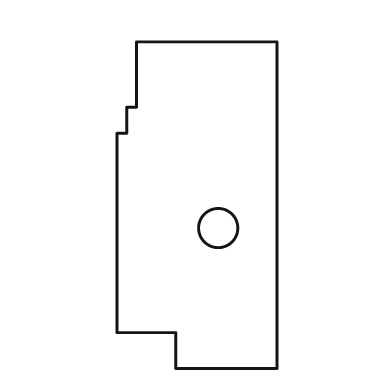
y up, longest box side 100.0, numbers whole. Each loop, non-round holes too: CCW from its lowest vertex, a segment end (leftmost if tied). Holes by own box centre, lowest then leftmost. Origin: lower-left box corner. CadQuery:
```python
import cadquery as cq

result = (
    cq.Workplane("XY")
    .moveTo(18.0, 0.0)
    .lineTo(49.0, 0.0)
    .lineTo(49.0, 100.0)
    .lineTo(6.0, 100.0)
    .lineTo(6.0, 80.0)
    .lineTo(3.0, 80.0)
    .lineTo(3.0, 72.0)
    .lineTo(0.0, 72.0)
    .lineTo(0.0, 11.0)
    .lineTo(18.0, 11.0)
    .close()
    .moveTo(31.0, 43.0)
    .circle(6.0)
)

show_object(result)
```